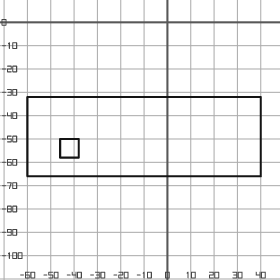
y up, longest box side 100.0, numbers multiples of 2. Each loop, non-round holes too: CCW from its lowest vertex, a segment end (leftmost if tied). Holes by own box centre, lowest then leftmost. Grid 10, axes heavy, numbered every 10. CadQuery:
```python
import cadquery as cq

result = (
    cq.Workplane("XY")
    .moveTo(-60.0, -66.0)
    .lineTo(40.0, -66.0)
    .lineTo(40.0, -32.0)
    .lineTo(-60.0, -32.0)
    .close()
    .moveTo(-46.0, -58.0)
    .lineTo(-38.0, -58.0)
    .lineTo(-38.0, -50.0)
    .lineTo(-46.0, -50.0)
    .close()
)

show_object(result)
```